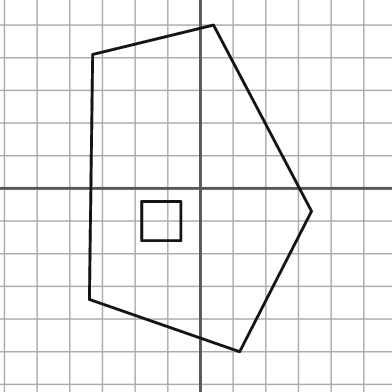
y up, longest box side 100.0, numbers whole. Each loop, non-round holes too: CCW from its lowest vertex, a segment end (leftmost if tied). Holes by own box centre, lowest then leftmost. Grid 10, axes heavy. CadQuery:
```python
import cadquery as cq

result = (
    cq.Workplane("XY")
    .moveTo(12.0, -50.0)
    .lineTo(34.0, -7.0)
    .lineTo(4.0, 50.0)
    .lineTo(-33.0, 41.0)
    .lineTo(-34.0, -34.0)
    .close()
    .moveTo(-18.0, -16.0)
    .lineTo(-6.0, -16.0)
    .lineTo(-6.0, -4.0)
    .lineTo(-18.0, -4.0)
    .close()
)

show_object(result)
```